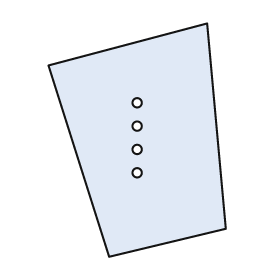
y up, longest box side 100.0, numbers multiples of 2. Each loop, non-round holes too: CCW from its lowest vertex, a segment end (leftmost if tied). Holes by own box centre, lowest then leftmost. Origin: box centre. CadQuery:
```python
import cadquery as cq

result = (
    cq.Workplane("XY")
    .moveTo(-12.0, -50.0)
    .lineTo(38.0, -38.0)
    .lineTo(30.0, 50.0)
    .lineTo(-38.0, 32.0)
    .close()
    .moveTo(0.0, -14.0)
    .circle(2.0)
    .moveTo(0.0, -4.0)
    .circle(2.0)
    .moveTo(0.0, 6.0)
    .circle(2.0)
    .moveTo(0.0, 16.0)
    .circle(2.0)
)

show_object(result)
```